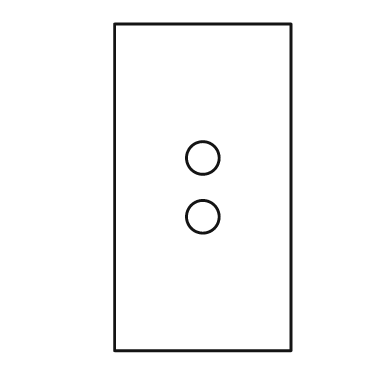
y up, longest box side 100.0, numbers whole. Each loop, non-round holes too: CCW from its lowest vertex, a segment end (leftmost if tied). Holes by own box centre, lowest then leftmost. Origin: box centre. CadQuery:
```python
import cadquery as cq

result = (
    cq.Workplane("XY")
    .moveTo(-27.0, -50.0)
    .lineTo(27.0, -50.0)
    .lineTo(27.0, 50.0)
    .lineTo(-27.0, 50.0)
    .close()
    .moveTo(0.0, -9.0)
    .circle(5.0)
    .moveTo(0.0, 9.0)
    .circle(5.0)
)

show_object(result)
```